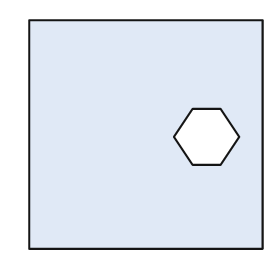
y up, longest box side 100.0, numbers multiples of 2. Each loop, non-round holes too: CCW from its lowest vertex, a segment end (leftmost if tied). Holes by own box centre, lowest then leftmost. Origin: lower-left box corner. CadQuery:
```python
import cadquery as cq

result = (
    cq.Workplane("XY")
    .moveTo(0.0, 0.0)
    .lineTo(100.0, 0.0)
    .lineTo(100.0, 98.0)
    .lineTo(0.0, 98.0)
    .close()
    .moveTo(70.0, 36.0)
    .lineTo(82.0, 36.0)
    .lineTo(90.0, 48.0)
    .lineTo(82.0, 60.0)
    .lineTo(70.0, 60.0)
    .lineTo(62.0, 48.0)
    .close()
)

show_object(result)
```